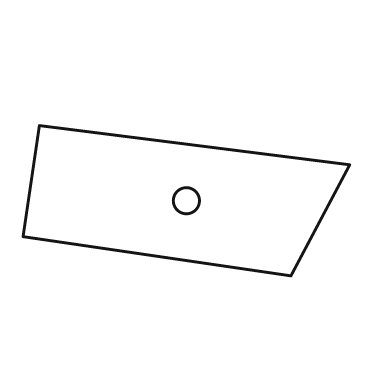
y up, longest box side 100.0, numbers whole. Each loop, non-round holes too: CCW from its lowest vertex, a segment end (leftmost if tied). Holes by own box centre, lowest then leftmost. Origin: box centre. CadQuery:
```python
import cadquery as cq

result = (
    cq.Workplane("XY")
    .moveTo(32.0, -23.0)
    .lineTo(50.0, 11.0)
    .lineTo(-45.0, 23.0)
    .lineTo(-50.0, -11.0)
    .close()
    .moveTo(0.0, 0.0)
    .circle(4.0)
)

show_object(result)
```